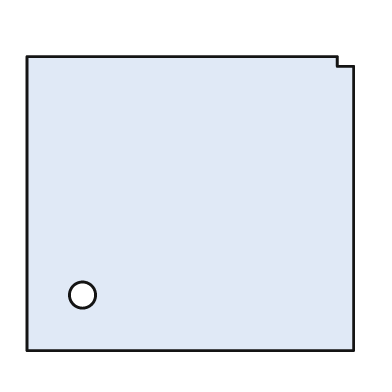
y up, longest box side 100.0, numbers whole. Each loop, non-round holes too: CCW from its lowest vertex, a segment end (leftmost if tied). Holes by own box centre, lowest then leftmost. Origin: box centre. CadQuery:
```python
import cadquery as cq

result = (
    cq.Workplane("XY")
    .moveTo(-50.0, -45.0)
    .lineTo(50.0, -45.0)
    .lineTo(50.0, 42.0)
    .lineTo(45.0, 42.0)
    .lineTo(45.0, 45.0)
    .lineTo(-50.0, 45.0)
    .close()
    .moveTo(-33.0, -28.0)
    .circle(4.0)
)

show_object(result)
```